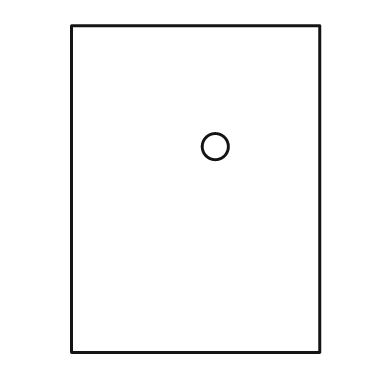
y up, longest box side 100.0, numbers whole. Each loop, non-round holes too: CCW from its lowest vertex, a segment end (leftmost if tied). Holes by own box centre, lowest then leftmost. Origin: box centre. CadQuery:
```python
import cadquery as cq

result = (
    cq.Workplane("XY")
    .moveTo(-38.0, -50.0)
    .lineTo(38.0, -50.0)
    .lineTo(38.0, 50.0)
    .lineTo(-38.0, 50.0)
    .close()
    .moveTo(6.0, 13.0)
    .circle(4.0)
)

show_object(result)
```